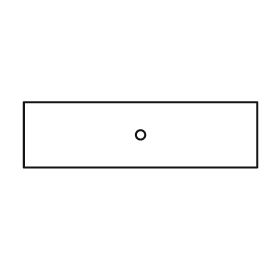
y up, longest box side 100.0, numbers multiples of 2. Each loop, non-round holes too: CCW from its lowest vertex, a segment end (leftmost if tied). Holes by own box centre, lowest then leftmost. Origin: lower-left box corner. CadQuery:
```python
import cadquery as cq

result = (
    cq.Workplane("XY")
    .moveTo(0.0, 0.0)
    .lineTo(100.0, 0.0)
    .lineTo(100.0, 28.0)
    .lineTo(0.0, 28.0)
    .close()
    .moveTo(50.0, 14.0)
    .circle(2.0)
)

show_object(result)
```